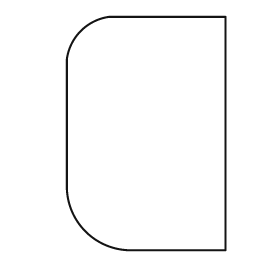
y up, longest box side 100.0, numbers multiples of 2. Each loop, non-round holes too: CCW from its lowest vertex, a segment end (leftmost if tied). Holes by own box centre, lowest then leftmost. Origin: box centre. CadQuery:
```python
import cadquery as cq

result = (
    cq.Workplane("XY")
    .moveTo(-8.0, -50.0)
    .lineTo(34.0, -50.0)
    .lineTo(34.0, 50.0)
    .lineTo(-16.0, 50.0)
    .threePointArc((-28.0, 44.0), (-34.0, 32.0))
    .lineTo(-34.0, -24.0)
    .threePointArc((-26.0, -42.0), (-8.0, -50.0))
    .close()
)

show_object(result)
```